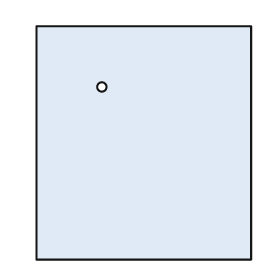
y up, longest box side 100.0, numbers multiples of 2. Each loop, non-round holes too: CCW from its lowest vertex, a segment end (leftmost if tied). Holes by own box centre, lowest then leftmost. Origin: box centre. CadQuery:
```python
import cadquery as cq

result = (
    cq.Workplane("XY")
    .moveTo(-46.0, -50.0)
    .lineTo(46.0, -50.0)
    .lineTo(46.0, 50.0)
    .lineTo(-46.0, 50.0)
    .close()
    .moveTo(-18.0, 24.0)
    .circle(2.0)
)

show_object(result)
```